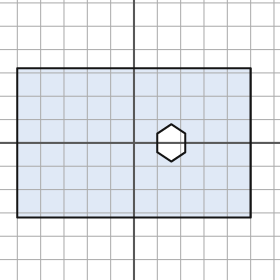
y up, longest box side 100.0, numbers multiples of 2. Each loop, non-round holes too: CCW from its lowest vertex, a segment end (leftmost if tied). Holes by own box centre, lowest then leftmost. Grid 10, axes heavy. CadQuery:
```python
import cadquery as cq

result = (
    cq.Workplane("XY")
    .moveTo(-50.0, -32.0)
    .lineTo(50.0, -32.0)
    .lineTo(50.0, 32.0)
    .lineTo(-50.0, 32.0)
    .close()
    .moveTo(16.0, -8.0)
    .lineTo(22.0, -4.0)
    .lineTo(22.0, 4.0)
    .lineTo(16.0, 8.0)
    .lineTo(10.0, 4.0)
    .lineTo(10.0, -4.0)
    .close()
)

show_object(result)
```